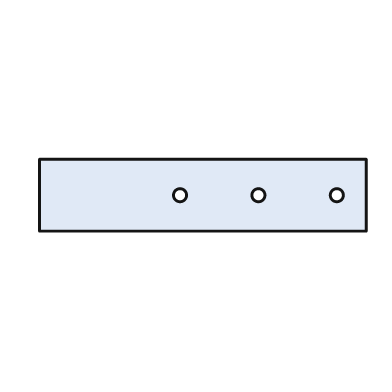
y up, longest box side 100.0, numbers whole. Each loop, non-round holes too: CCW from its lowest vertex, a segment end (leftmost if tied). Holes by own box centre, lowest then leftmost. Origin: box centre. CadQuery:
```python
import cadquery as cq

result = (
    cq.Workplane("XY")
    .moveTo(-50.0, -11.0)
    .lineTo(50.0, -11.0)
    .lineTo(50.0, 11.0)
    .lineTo(-50.0, 11.0)
    .close()
    .moveTo(-7.0, 0.0)
    .circle(2.0)
    .moveTo(17.0, 0.0)
    .circle(2.0)
    .moveTo(41.0, 0.0)
    .circle(2.0)
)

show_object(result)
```